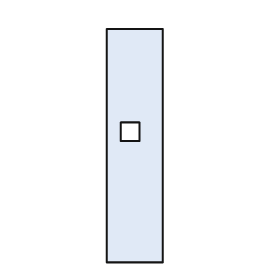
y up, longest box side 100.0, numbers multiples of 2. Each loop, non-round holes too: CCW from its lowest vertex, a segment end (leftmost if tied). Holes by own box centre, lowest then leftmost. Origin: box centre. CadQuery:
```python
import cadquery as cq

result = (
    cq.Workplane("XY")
    .moveTo(-12.0, -50.0)
    .lineTo(12.0, -50.0)
    .lineTo(12.0, 50.0)
    .lineTo(-12.0, 50.0)
    .close()
    .moveTo(-6.0, 2.0)
    .lineTo(2.0, 2.0)
    .lineTo(2.0, 10.0)
    .lineTo(-6.0, 10.0)
    .close()
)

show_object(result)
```